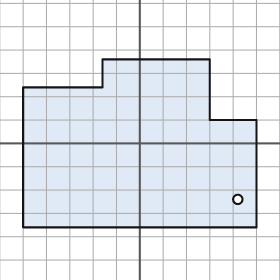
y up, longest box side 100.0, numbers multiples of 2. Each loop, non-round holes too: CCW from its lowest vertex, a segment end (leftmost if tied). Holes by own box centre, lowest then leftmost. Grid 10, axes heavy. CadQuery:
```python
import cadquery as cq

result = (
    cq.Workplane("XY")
    .moveTo(-50.0, -36.0)
    .lineTo(50.0, -36.0)
    .lineTo(50.0, 10.0)
    .lineTo(30.0, 10.0)
    .lineTo(30.0, 36.0)
    .lineTo(-16.0, 36.0)
    .lineTo(-16.0, 24.0)
    .lineTo(-50.0, 24.0)
    .close()
    .moveTo(42.0, -24.0)
    .circle(2.0)
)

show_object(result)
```